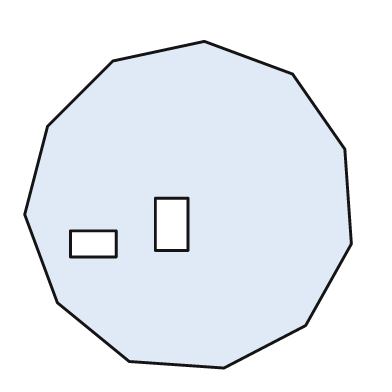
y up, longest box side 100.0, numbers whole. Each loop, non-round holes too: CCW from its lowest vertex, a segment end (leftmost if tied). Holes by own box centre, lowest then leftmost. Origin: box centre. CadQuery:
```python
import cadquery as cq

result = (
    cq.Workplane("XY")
    .moveTo(11.0, -50.0)
    .lineTo(36.0, -37.0)
    .lineTo(50.0, -12.0)
    .lineTo(48.0, 17.0)
    .lineTo(32.0, 40.0)
    .lineTo(5.0, 50.0)
    .lineTo(-23.0, 44.0)
    .lineTo(-43.0, 24.0)
    .lineTo(-50.0, -3.0)
    .lineTo(-40.0, -30.0)
    .lineTo(-18.0, -48.0)
    .close()
    .moveTo(-36.0, -16.0)
    .lineTo(-22.0, -16.0)
    .lineTo(-22.0, -8.0)
    .lineTo(-36.0, -8.0)
    .close()
    .moveTo(-10.0, -14.0)
    .lineTo(0.0, -14.0)
    .lineTo(0.0, 2.0)
    .lineTo(-10.0, 2.0)
    .close()
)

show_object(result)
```